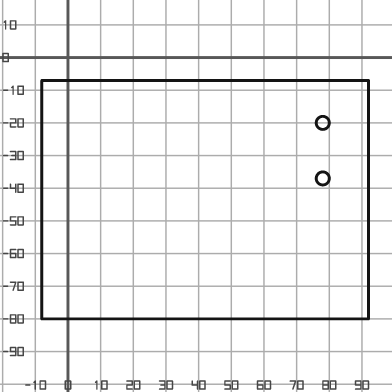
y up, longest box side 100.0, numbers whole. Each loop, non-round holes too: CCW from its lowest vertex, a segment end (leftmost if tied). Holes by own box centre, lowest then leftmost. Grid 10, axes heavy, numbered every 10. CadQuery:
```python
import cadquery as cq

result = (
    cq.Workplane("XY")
    .moveTo(-8.0, -80.0)
    .lineTo(92.0, -80.0)
    .lineTo(92.0, -7.0)
    .lineTo(-8.0, -7.0)
    .close()
    .moveTo(78.0, -37.0)
    .circle(2.0)
    .moveTo(78.0, -20.0)
    .circle(2.0)
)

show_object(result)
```